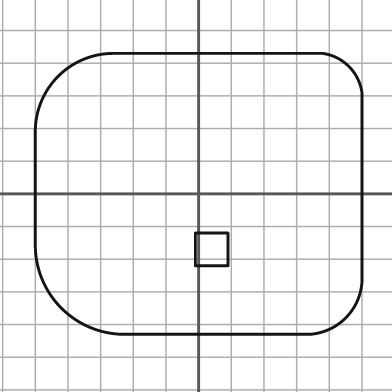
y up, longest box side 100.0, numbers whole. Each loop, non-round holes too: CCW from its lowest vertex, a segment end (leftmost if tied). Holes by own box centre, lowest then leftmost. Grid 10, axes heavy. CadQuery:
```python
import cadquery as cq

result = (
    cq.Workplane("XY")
    .moveTo(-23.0, -43.0)
    .lineTo(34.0, -43.0)
    .threePointArc((45.0, -38.0), (50.0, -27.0))
    .lineTo(50.0, 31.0)
    .threePointArc((46.0, 39.0), (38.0, 43.0))
    .lineTo(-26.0, 43.0)
    .threePointArc((-43.0, 36.0), (-50.0, 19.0))
    .lineTo(-50.0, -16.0)
    .threePointArc((-42.0, -35.0), (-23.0, -43.0))
    .close()
    .moveTo(-1.0, -22.0)
    .lineTo(9.0, -22.0)
    .lineTo(9.0, -12.0)
    .lineTo(-1.0, -12.0)
    .close()
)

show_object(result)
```